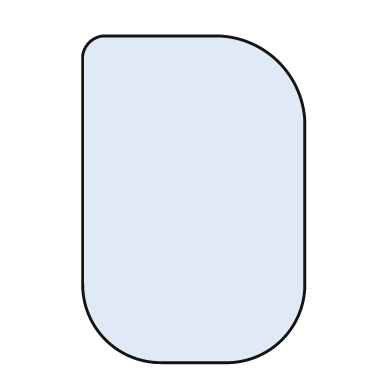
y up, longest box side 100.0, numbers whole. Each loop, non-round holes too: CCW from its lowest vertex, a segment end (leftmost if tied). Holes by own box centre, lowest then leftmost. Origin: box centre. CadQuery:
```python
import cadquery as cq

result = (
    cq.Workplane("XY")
    .moveTo(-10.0, -50.0)
    .lineTo(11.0, -50.0)
    .threePointArc((27.0, -43.0), (34.0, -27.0))
    .lineTo(34.0, 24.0)
    .threePointArc((26.0, 42.0), (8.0, 50.0))
    .lineTo(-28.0, 50.0)
    .threePointArc((-32.0, 48.0), (-34.0, 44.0))
    .lineTo(-34.0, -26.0)
    .threePointArc((-27.0, -43.0), (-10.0, -50.0))
    .close()
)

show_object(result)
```